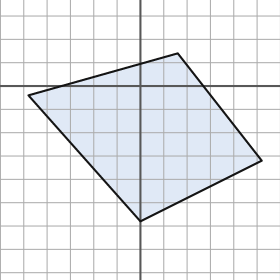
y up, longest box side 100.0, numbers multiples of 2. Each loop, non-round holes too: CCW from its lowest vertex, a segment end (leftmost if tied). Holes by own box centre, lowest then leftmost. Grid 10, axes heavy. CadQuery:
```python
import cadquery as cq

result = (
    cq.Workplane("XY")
    .moveTo(0.0, -58.0)
    .lineTo(52.0, -32.0)
    .lineTo(16.0, 14.0)
    .lineTo(-48.0, -4.0)
    .close()
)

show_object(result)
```